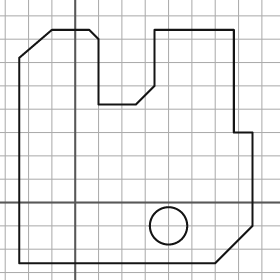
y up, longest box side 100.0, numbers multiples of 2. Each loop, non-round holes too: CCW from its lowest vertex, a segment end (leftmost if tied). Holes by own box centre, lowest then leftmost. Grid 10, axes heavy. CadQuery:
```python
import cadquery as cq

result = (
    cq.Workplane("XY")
    .moveTo(-24.0, -26.0)
    .lineTo(60.0, -26.0)
    .lineTo(76.0, -10.0)
    .lineTo(76.0, 30.0)
    .lineTo(68.0, 30.0)
    .lineTo(68.0, 74.0)
    .lineTo(34.0, 74.0)
    .lineTo(34.0, 50.0)
    .lineTo(26.0, 42.0)
    .lineTo(10.0, 42.0)
    .lineTo(10.0, 70.0)
    .lineTo(6.0, 74.0)
    .lineTo(-10.0, 74.0)
    .lineTo(-24.0, 62.0)
    .close()
    .moveTo(40.0, -10.0)
    .circle(8.0)
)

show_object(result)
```